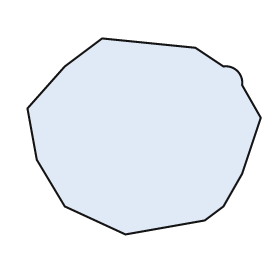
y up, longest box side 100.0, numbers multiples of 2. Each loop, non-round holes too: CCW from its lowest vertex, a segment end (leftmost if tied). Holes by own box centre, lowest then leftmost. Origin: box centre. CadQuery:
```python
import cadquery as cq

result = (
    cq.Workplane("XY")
    .moveTo(-8.0, -42.0)
    .lineTo(26.0, -36.0)
    .lineTo(34.0, -30.0)
    .lineTo(42.0, -16.0)
    .lineTo(50.0, 8.0)
    .lineTo(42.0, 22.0)
    .threePointArc((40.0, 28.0), (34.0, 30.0))
    .lineTo(22.0, 38.0)
    .lineTo(-18.0, 42.0)
    .lineTo(-34.0, 30.0)
    .lineTo(-50.0, 12.0)
    .lineTo(-46.0, -10.0)
    .lineTo(-34.0, -30.0)
    .close()
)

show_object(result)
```